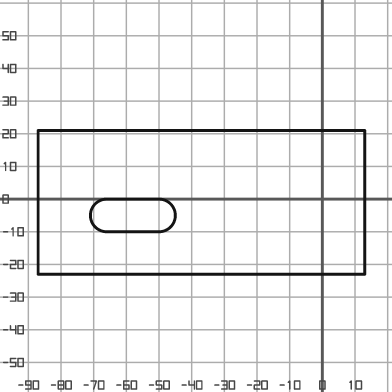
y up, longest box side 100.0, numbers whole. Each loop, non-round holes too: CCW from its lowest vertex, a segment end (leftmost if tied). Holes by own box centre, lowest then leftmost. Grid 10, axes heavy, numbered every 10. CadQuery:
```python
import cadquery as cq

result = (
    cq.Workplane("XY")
    .moveTo(-87.0, -23.0)
    .lineTo(13.0, -23.0)
    .lineTo(13.0, 21.0)
    .lineTo(-87.0, 21.0)
    .close()
    .moveTo(-66.0, -10.0)
    .lineTo(-50.0, -10.0)
    .threePointArc((-45.0, -5.0), (-50.0, 0.0))
    .lineTo(-66.0, 0.0)
    .threePointArc((-71.0, -5.0), (-66.0, -10.0))
    .close()
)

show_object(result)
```